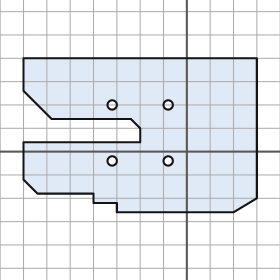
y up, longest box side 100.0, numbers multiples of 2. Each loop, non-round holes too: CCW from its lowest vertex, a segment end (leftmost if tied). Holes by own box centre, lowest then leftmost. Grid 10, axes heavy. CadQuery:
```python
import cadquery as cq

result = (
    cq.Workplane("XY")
    .moveTo(-30.0, -26.0)
    .lineTo(20.0, -26.0)
    .lineTo(30.0, -20.0)
    .lineTo(30.0, 40.0)
    .lineTo(-70.0, 40.0)
    .lineTo(-70.0, 26.0)
    .lineTo(-58.0, 14.0)
    .lineTo(-24.0, 14.0)
    .lineTo(-20.0, 10.0)
    .lineTo(-20.0, 4.0)
    .lineTo(-70.0, 4.0)
    .lineTo(-70.0, -12.0)
    .lineTo(-64.0, -18.0)
    .lineTo(-40.0, -18.0)
    .lineTo(-40.0, -22.0)
    .lineTo(-30.0, -22.0)
    .close()
    .moveTo(-32.0, -4.0)
    .circle(2.0)
    .moveTo(-8.0, -4.0)
    .circle(2.0)
    .moveTo(-32.0, 20.0)
    .circle(2.0)
    .moveTo(-8.0, 20.0)
    .circle(2.0)
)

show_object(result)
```